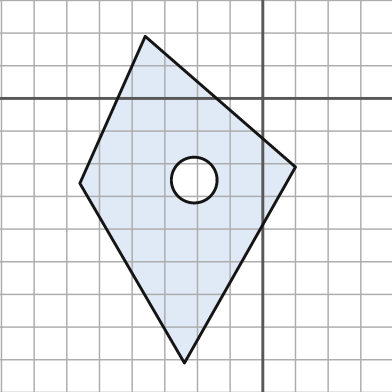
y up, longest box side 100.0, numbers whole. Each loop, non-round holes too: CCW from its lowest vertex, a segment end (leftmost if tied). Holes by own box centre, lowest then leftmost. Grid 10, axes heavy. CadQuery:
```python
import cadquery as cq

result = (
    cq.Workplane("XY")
    .moveTo(-24.0, -81.0)
    .lineTo(10.0, -21.0)
    .lineTo(-36.0, 19.0)
    .lineTo(-56.0, -26.0)
    .close()
    .moveTo(-21.0, -25.0)
    .circle(7.0)
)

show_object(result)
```